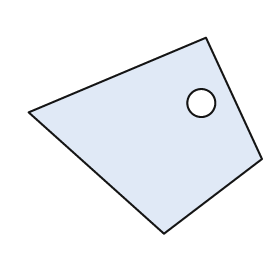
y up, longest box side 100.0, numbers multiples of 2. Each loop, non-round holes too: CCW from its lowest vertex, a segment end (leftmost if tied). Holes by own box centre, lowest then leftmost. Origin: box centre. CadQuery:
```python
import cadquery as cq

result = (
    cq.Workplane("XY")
    .moveTo(8.0, -42.0)
    .lineTo(50.0, -10.0)
    .lineTo(26.0, 42.0)
    .lineTo(-50.0, 10.0)
    .close()
    .moveTo(24.0, 14.0)
    .circle(6.0)
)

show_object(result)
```